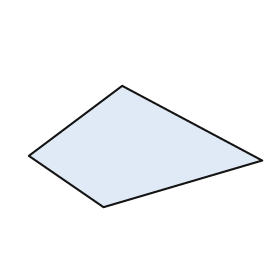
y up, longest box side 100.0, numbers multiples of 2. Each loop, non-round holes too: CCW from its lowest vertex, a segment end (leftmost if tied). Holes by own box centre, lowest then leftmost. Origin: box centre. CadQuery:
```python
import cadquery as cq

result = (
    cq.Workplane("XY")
    .moveTo(-18.0, -26.0)
    .lineTo(50.0, -6.0)
    .lineTo(-10.0, 26.0)
    .lineTo(-50.0, -4.0)
    .close()
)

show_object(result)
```